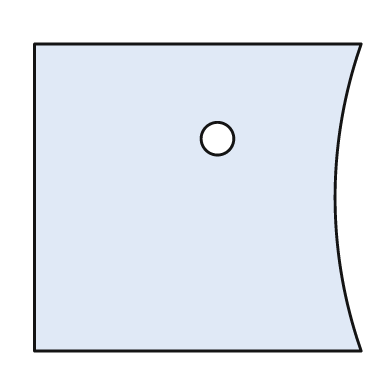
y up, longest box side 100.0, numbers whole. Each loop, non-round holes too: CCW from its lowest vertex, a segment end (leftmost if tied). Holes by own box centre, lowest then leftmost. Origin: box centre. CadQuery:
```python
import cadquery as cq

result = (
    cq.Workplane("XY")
    .moveTo(-50.0, -47.0)
    .lineTo(50.0, -47.0)
    .threePointArc((42.0, 0.0), (50.0, 47.0))
    .lineTo(-50.0, 47.0)
    .close()
    .moveTo(6.0, 18.0)
    .circle(5.0)
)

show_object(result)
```